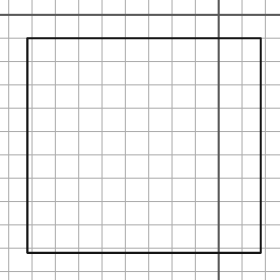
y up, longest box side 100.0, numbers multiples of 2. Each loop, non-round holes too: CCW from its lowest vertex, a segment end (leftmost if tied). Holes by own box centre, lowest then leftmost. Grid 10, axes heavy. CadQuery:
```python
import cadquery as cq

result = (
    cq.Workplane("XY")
    .moveTo(-82.0, -102.0)
    .lineTo(18.0, -102.0)
    .lineTo(18.0, -10.0)
    .lineTo(-82.0, -10.0)
    .close()
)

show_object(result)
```